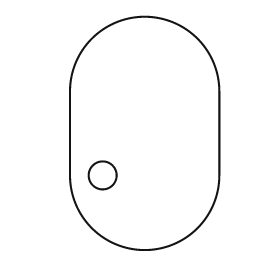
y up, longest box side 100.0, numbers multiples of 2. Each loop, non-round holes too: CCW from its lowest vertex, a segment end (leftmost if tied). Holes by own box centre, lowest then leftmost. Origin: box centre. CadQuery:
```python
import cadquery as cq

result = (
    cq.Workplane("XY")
    .moveTo(-32.0, -18.0)
    .threePointArc((0.0, -50.0), (32.0, -18.0))
    .lineTo(32.0, 18.0)
    .threePointArc((0.0, 50.0), (-32.0, 18.0))
    .close()
    .moveTo(-18.0, -18.0)
    .circle(6.0)
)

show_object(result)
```